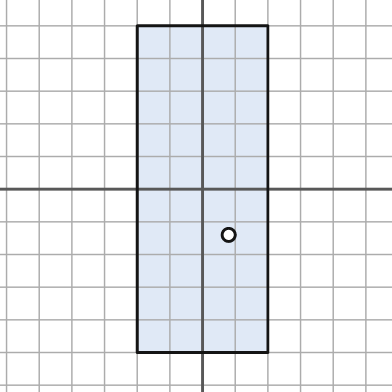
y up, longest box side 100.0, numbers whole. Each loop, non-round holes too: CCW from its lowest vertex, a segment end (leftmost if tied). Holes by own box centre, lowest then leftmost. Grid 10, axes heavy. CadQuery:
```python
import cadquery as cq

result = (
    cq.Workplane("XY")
    .moveTo(-20.0, -50.0)
    .lineTo(20.0, -50.0)
    .lineTo(20.0, 50.0)
    .lineTo(-20.0, 50.0)
    .close()
    .moveTo(8.0, -14.0)
    .circle(2.0)
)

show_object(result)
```